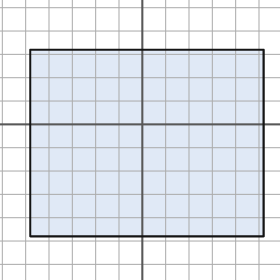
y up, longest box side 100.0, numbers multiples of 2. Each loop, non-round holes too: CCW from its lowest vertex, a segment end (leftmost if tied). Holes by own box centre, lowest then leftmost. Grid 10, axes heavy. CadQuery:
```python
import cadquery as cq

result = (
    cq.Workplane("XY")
    .moveTo(-48.0, -48.0)
    .lineTo(52.0, -48.0)
    .lineTo(52.0, 32.0)
    .lineTo(-48.0, 32.0)
    .close()
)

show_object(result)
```